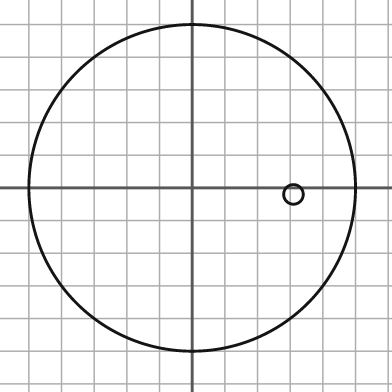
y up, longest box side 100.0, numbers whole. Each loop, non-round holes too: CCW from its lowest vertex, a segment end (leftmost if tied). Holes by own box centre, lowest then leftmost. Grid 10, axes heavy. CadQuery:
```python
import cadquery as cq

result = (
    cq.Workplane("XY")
    .moveTo(0.0, 0.0)
    .circle(50.0)
    .moveTo(31.0, -2.0)
    .circle(3.0)
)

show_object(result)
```